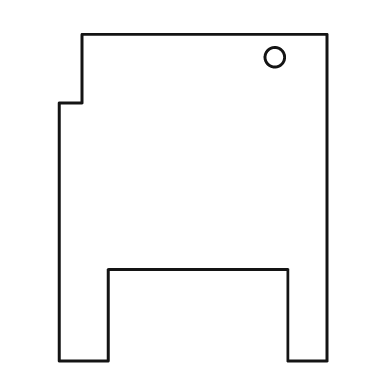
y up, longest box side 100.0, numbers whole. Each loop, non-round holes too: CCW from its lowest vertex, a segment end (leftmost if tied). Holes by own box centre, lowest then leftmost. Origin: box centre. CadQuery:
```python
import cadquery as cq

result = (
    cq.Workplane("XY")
    .moveTo(-41.0, -50.0)
    .lineTo(-26.0, -50.0)
    .lineTo(-26.0, -22.0)
    .lineTo(29.0, -22.0)
    .lineTo(29.0, -50.0)
    .lineTo(41.0, -50.0)
    .lineTo(41.0, 50.0)
    .lineTo(-34.0, 50.0)
    .lineTo(-34.0, 29.0)
    .lineTo(-41.0, 29.0)
    .close()
    .moveTo(25.0, 43.0)
    .circle(3.0)
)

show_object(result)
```